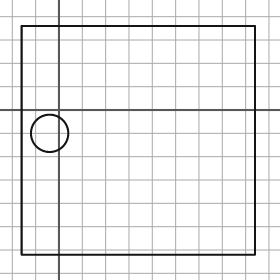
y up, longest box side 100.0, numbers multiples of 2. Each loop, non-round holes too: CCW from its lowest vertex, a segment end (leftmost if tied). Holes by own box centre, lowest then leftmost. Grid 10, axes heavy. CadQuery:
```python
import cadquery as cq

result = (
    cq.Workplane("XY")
    .moveTo(-16.0, -62.0)
    .lineTo(84.0, -62.0)
    .lineTo(84.0, 36.0)
    .lineTo(-16.0, 36.0)
    .close()
    .moveTo(-4.0, -10.0)
    .circle(8.0)
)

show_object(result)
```